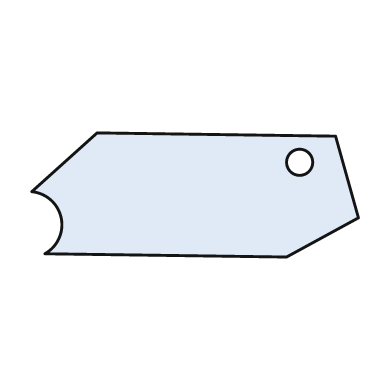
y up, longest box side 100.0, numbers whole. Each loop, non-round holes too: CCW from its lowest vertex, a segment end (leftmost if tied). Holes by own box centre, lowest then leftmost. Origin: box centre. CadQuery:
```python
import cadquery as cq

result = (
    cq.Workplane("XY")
    .moveTo(28.0, -19.0)
    .lineTo(50.0, -7.0)
    .lineTo(43.0, 18.0)
    .lineTo(-30.0, 19.0)
    .lineTo(-50.0, 1.0)
    .threePointArc((-41.0, -7.0), (-46.0, -18.0))
    .close()
    .moveTo(32.0, 10.0)
    .circle(4.0)
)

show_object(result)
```